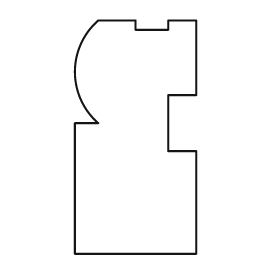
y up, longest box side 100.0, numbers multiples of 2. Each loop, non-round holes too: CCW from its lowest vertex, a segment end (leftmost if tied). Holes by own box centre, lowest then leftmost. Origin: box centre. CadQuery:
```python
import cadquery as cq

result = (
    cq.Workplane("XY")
    .moveTo(-26.0, -50.0)
    .lineTo(26.0, -50.0)
    .lineTo(26.0, -6.0)
    .lineTo(14.0, -6.0)
    .lineTo(14.0, 18.0)
    .lineTo(26.0, 18.0)
    .lineTo(26.0, 50.0)
    .lineTo(14.0, 50.0)
    .lineTo(14.0, 46.0)
    .lineTo(0.0, 46.0)
    .lineTo(0.0, 50.0)
    .lineTo(-16.0, 50.0)
    .threePointArc((-26.0, 28.0), (-16.0, 6.0))
    .lineTo(-26.0, 6.0)
    .close()
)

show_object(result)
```